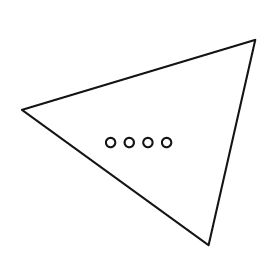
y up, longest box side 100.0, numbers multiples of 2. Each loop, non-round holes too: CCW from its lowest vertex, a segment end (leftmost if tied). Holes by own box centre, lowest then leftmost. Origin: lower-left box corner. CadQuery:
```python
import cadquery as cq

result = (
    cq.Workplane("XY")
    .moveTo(80.0, 0.0)
    .lineTo(100.0, 88.0)
    .lineTo(0.0, 58.0)
    .close()
    .moveTo(38.0, 44.0)
    .circle(2.0)
    .moveTo(46.0, 44.0)
    .circle(2.0)
    .moveTo(54.0, 44.0)
    .circle(2.0)
    .moveTo(62.0, 44.0)
    .circle(2.0)
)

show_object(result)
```